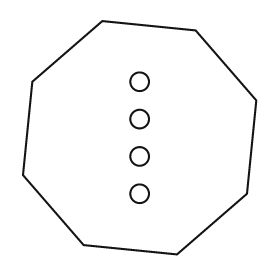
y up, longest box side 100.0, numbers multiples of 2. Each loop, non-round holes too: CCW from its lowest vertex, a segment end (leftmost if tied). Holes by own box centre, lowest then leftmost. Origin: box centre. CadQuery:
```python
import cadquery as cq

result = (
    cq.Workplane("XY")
    .moveTo(16.0, -50.0)
    .lineTo(46.0, -24.0)
    .lineTo(50.0, 16.0)
    .lineTo(24.0, 46.0)
    .lineTo(-16.0, 50.0)
    .lineTo(-46.0, 24.0)
    .lineTo(-50.0, -16.0)
    .lineTo(-24.0, -46.0)
    .close()
    .moveTo(0.0, -24.0)
    .circle(4.0)
    .moveTo(0.0, -8.0)
    .circle(4.0)
    .moveTo(0.0, 8.0)
    .circle(4.0)
    .moveTo(0.0, 24.0)
    .circle(4.0)
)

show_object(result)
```